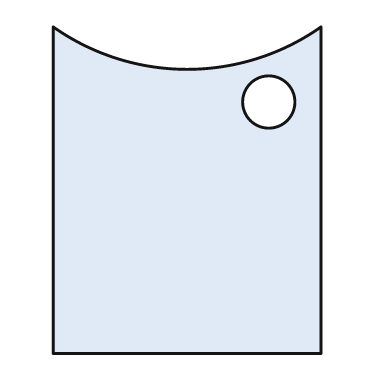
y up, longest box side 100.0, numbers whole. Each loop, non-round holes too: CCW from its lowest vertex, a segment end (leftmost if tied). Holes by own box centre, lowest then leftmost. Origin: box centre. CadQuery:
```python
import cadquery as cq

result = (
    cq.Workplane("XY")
    .moveTo(-41.0, -50.0)
    .lineTo(41.0, -50.0)
    .lineTo(41.0, 50.0)
    .threePointArc((0.0, 37.0), (-41.0, 50.0))
    .close()
    .moveTo(25.0, 27.0)
    .circle(8.0)
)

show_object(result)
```